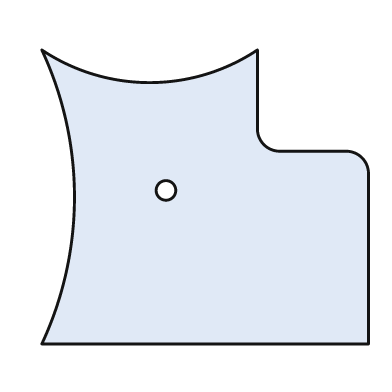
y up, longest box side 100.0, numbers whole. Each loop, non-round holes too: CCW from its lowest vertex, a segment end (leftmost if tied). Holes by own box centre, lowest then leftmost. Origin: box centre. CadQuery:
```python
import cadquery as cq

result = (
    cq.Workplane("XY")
    .moveTo(-50.0, -45.0)
    .lineTo(50.0, -45.0)
    .lineTo(50.0, 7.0)
    .threePointArc((48.0, 12.0), (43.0, 14.0))
    .lineTo(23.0, 14.0)
    .threePointArc((18.0, 16.0), (16.0, 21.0))
    .lineTo(16.0, 45.0)
    .threePointArc((-17.0, 35.0), (-50.0, 45.0))
    .threePointArc((-40.0, 0.0), (-50.0, -45.0))
    .close()
    .moveTo(-12.0, 2.0)
    .circle(3.0)
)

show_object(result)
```